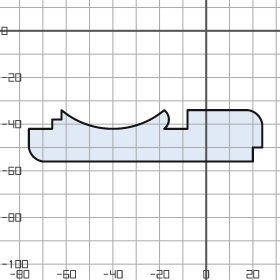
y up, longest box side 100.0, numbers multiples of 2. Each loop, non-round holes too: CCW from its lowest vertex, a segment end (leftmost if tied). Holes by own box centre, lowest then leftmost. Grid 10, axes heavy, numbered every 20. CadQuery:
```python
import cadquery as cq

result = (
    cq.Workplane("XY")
    .moveTo(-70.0, -56.0)
    .lineTo(20.0, -56.0)
    .lineTo(20.0, -50.0)
    .lineTo(24.0, -50.0)
    .lineTo(24.0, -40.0)
    .threePointArc((22.0, -36.0), (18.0, -34.0))
    .lineTo(-8.0, -34.0)
    .lineTo(-8.0, -42.0)
    .lineTo(-18.0, -42.0)
    .threePointArc((-16.0, -38.0), (-18.0, -34.0))
    .threePointArc((-40.0, -42.0), (-62.0, -34.0))
    .lineTo(-62.0, -38.0)
    .lineTo(-66.0, -38.0)
    .lineTo(-66.0, -42.0)
    .lineTo(-76.0, -42.0)
    .lineTo(-76.0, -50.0)
    .threePointArc((-74.0, -54.0), (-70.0, -56.0))
    .close()
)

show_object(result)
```